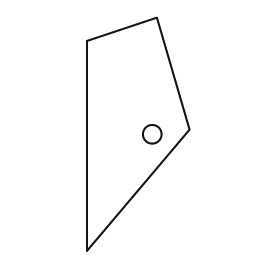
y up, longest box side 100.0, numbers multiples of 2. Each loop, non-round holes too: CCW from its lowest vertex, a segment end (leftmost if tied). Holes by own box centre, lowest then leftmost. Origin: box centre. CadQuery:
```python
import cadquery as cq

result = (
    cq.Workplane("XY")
    .moveTo(-22.0, -50.0)
    .lineTo(22.0, 2.0)
    .lineTo(8.0, 50.0)
    .lineTo(-22.0, 40.0)
    .close()
    .moveTo(6.0, 0.0)
    .circle(4.0)
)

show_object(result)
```